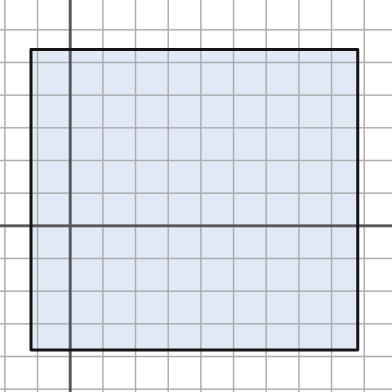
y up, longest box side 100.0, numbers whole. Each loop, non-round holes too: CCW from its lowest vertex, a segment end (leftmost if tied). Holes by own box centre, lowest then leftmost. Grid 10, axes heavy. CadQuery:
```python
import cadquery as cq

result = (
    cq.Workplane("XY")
    .moveTo(-12.0, -38.0)
    .lineTo(88.0, -38.0)
    .lineTo(88.0, 54.0)
    .lineTo(-12.0, 54.0)
    .close()
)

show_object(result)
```